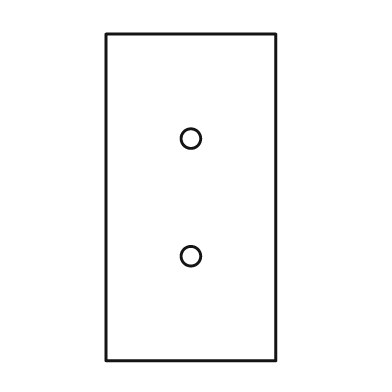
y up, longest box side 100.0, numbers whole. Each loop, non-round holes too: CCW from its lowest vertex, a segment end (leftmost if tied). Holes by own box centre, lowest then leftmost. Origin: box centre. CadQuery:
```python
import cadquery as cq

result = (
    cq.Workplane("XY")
    .moveTo(-26.0, -50.0)
    .lineTo(26.0, -50.0)
    .lineTo(26.0, 50.0)
    .lineTo(-26.0, 50.0)
    .close()
    .moveTo(0.0, -18.0)
    .circle(3.0)
    .moveTo(0.0, 18.0)
    .circle(3.0)
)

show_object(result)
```